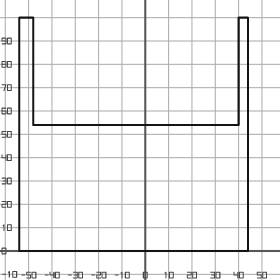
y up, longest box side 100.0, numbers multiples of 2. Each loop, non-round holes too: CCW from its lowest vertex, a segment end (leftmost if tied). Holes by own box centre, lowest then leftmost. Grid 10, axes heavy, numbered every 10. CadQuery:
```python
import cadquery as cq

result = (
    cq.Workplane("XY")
    .moveTo(-54.0, 0.0)
    .lineTo(44.0, 0.0)
    .lineTo(44.0, 100.0)
    .lineTo(40.0, 100.0)
    .lineTo(40.0, 54.0)
    .lineTo(-48.0, 54.0)
    .lineTo(-48.0, 100.0)
    .lineTo(-54.0, 100.0)
    .close()
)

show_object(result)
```